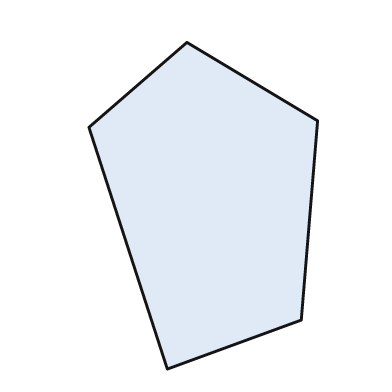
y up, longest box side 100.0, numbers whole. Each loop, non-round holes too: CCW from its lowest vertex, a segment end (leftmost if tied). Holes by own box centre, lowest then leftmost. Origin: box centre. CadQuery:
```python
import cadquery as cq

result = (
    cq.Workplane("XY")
    .moveTo(-11.0, -50.0)
    .lineTo(30.0, -35.0)
    .lineTo(35.0, 26.0)
    .lineTo(-5.0, 50.0)
    .lineTo(-35.0, 24.0)
    .close()
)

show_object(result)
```